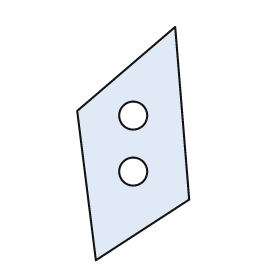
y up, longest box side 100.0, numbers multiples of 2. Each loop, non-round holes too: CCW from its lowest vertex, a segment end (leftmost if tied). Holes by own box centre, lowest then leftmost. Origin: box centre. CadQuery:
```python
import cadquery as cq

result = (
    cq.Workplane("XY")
    .moveTo(-16.0, -50.0)
    .lineTo(24.0, -24.0)
    .lineTo(18.0, 50.0)
    .lineTo(-24.0, 14.0)
    .close()
    .moveTo(0.0, -12.0)
    .circle(6.0)
    .moveTo(0.0, 12.0)
    .circle(6.0)
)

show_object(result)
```